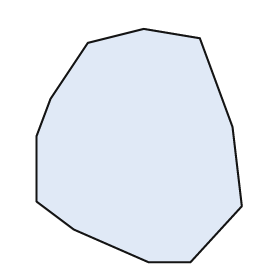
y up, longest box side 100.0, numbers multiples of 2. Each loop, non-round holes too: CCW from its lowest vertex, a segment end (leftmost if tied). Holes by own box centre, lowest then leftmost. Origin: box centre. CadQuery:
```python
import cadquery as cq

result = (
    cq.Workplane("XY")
    .moveTo(4.0, -50.0)
    .lineTo(22.0, -50.0)
    .lineTo(44.0, -26.0)
    .lineTo(40.0, 8.0)
    .lineTo(26.0, 46.0)
    .lineTo(2.0, 50.0)
    .lineTo(-22.0, 44.0)
    .lineTo(-38.0, 20.0)
    .lineTo(-44.0, 4.0)
    .lineTo(-44.0, -24.0)
    .lineTo(-28.0, -36.0)
    .close()
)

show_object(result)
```